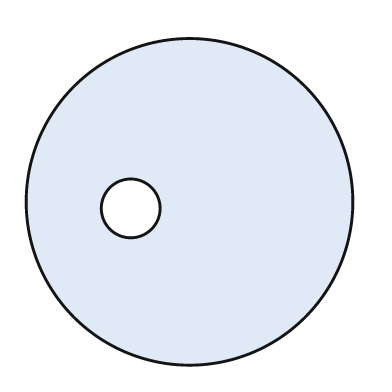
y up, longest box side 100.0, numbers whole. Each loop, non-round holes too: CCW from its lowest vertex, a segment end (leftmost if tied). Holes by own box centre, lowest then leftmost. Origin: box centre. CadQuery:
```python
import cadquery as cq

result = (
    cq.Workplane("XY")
    .moveTo(0.0, 0.0)
    .circle(50.0)
    .moveTo(-18.0, -2.0)
    .circle(9.0)
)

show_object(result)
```